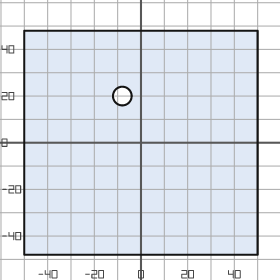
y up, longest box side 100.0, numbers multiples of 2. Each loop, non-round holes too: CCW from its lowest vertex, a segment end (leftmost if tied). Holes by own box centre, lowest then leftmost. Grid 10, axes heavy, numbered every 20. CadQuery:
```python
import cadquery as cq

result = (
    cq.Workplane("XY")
    .moveTo(-50.0, -48.0)
    .lineTo(50.0, -48.0)
    .lineTo(50.0, 48.0)
    .lineTo(-50.0, 48.0)
    .close()
    .moveTo(-8.0, 20.0)
    .circle(4.0)
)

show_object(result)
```